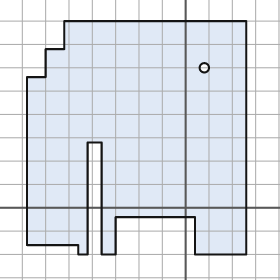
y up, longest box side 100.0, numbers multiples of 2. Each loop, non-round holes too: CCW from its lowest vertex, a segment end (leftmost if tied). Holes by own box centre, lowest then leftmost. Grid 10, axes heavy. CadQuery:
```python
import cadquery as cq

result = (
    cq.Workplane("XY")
    .moveTo(-46.0, -20.0)
    .lineTo(-42.0, -20.0)
    .lineTo(-42.0, 28.0)
    .lineTo(-36.0, 28.0)
    .lineTo(-36.0, -20.0)
    .lineTo(-30.0, -20.0)
    .lineTo(-30.0, -4.0)
    .lineTo(4.0, -4.0)
    .lineTo(4.0, -20.0)
    .lineTo(26.0, -20.0)
    .lineTo(26.0, 80.0)
    .lineTo(-52.0, 80.0)
    .lineTo(-52.0, 68.0)
    .lineTo(-60.0, 68.0)
    .lineTo(-60.0, 56.0)
    .lineTo(-68.0, 56.0)
    .lineTo(-68.0, -16.0)
    .lineTo(-46.0, -16.0)
    .close()
    .moveTo(8.0, 60.0)
    .circle(2.0)
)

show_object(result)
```